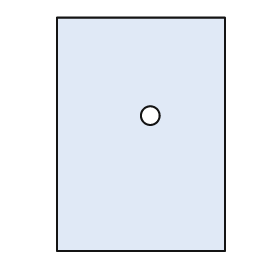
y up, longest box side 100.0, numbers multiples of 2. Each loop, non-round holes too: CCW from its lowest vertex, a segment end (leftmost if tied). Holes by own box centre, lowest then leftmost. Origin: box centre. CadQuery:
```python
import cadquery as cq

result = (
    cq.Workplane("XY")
    .moveTo(-36.0, -50.0)
    .lineTo(36.0, -50.0)
    .lineTo(36.0, 50.0)
    .lineTo(-36.0, 50.0)
    .close()
    .moveTo(4.0, 8.0)
    .circle(4.0)
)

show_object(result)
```